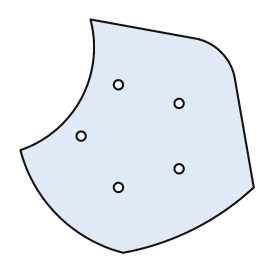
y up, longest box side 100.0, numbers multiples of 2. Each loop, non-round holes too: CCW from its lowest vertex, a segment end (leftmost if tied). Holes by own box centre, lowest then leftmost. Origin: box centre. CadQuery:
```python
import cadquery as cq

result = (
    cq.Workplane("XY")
    .moveTo(-6.0, -50.0)
    .threePointArc((24.0, -40.0), (50.0, -22.0))
    .lineTo(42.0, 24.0)
    .threePointArc((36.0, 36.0), (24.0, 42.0))
    .lineTo(-20.0, 50.0)
    .threePointArc((-24.0, 16.0), (-50.0, -6.0))
    .threePointArc((-34.0, -34.0), (-6.0, -50.0))
    .close()
    .moveTo(-8.0, -22.0)
    .circle(2.0)
    .moveTo(18.0, -14.0)
    .circle(2.0)
    .moveTo(-24.0, 0.0)
    .circle(2.0)
    .moveTo(18.0, 14.0)
    .circle(2.0)
    .moveTo(-8.0, 22.0)
    .circle(2.0)
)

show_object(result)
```